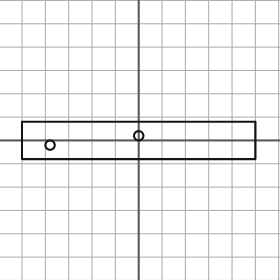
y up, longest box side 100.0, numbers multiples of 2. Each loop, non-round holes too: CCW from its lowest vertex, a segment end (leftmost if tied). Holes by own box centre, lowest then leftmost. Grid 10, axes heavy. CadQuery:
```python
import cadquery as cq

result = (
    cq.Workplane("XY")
    .moveTo(-50.0, -8.0)
    .lineTo(50.0, -8.0)
    .lineTo(50.0, 8.0)
    .lineTo(-50.0, 8.0)
    .close()
    .moveTo(-38.0, -2.0)
    .circle(2.0)
    .moveTo(0.0, 2.0)
    .circle(2.0)
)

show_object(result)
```